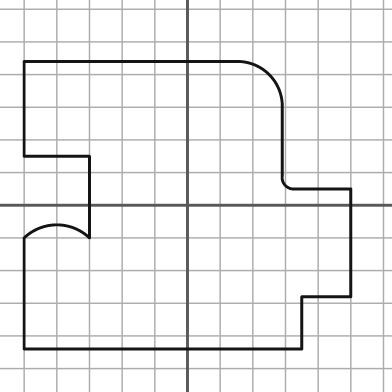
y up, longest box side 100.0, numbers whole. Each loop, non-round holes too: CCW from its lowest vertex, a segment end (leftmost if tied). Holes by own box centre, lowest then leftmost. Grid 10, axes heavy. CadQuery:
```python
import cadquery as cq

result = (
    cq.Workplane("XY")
    .moveTo(-50.0, -44.0)
    .lineTo(35.0, -44.0)
    .lineTo(35.0, -28.0)
    .lineTo(50.0, -28.0)
    .lineTo(50.0, 5.0)
    .lineTo(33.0, 5.0)
    .threePointArc((30.0, 6.0), (29.0, 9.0))
    .lineTo(29.0, 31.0)
    .threePointArc((25.0, 40.0), (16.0, 44.0))
    .lineTo(-50.0, 44.0)
    .lineTo(-50.0, 15.0)
    .lineTo(-30.0, 15.0)
    .lineTo(-30.0, -10.0)
    .threePointArc((-40.0, -6.0), (-50.0, -10.0))
    .close()
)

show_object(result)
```